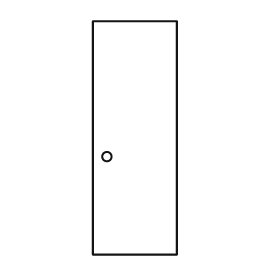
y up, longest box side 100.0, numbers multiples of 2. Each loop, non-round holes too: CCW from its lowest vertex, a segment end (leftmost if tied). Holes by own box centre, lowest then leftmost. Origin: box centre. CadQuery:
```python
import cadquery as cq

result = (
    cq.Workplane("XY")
    .moveTo(-18.0, -50.0)
    .lineTo(18.0, -50.0)
    .lineTo(18.0, 50.0)
    .lineTo(-18.0, 50.0)
    .close()
    .moveTo(-12.0, -8.0)
    .circle(2.0)
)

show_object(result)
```